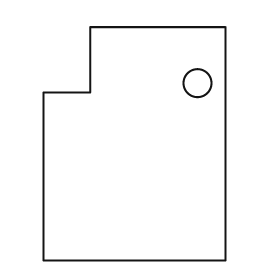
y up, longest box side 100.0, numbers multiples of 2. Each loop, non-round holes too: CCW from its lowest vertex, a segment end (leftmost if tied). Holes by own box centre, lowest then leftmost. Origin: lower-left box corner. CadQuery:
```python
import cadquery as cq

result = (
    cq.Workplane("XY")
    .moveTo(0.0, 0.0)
    .lineTo(78.0, 0.0)
    .lineTo(78.0, 100.0)
    .lineTo(20.0, 100.0)
    .lineTo(20.0, 72.0)
    .lineTo(0.0, 72.0)
    .close()
    .moveTo(66.0, 76.0)
    .circle(6.0)
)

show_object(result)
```